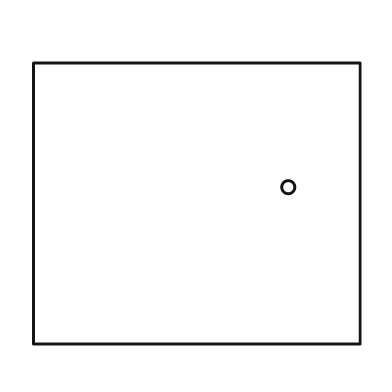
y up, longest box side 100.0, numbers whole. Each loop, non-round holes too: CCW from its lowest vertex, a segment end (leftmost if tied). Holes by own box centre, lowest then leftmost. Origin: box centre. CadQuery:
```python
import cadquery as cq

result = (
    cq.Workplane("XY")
    .moveTo(-50.0, -43.0)
    .lineTo(50.0, -43.0)
    .lineTo(50.0, 43.0)
    .lineTo(-50.0, 43.0)
    .close()
    .moveTo(28.0, 5.0)
    .circle(2.0)
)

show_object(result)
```